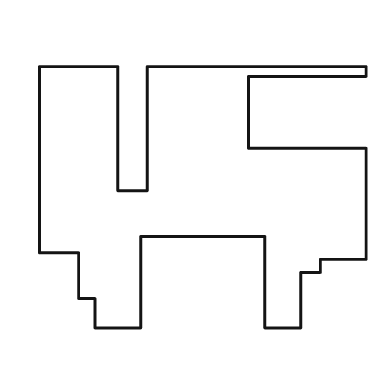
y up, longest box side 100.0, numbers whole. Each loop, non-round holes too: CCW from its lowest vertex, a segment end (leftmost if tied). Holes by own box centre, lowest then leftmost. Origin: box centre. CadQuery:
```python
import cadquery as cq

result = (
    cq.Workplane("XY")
    .moveTo(-33.0, -40.0)
    .lineTo(-19.0, -40.0)
    .lineTo(-19.0, -12.0)
    .lineTo(19.0, -12.0)
    .lineTo(19.0, -40.0)
    .lineTo(30.0, -40.0)
    .lineTo(30.0, -23.0)
    .lineTo(36.0, -23.0)
    .lineTo(36.0, -19.0)
    .lineTo(50.0, -19.0)
    .lineTo(50.0, 15.0)
    .lineTo(14.0, 15.0)
    .lineTo(14.0, 37.0)
    .lineTo(50.0, 37.0)
    .lineTo(50.0, 40.0)
    .lineTo(-17.0, 40.0)
    .lineTo(-17.0, 2.0)
    .lineTo(-26.0, 2.0)
    .lineTo(-26.0, 40.0)
    .lineTo(-50.0, 40.0)
    .lineTo(-50.0, -17.0)
    .lineTo(-38.0, -17.0)
    .lineTo(-38.0, -31.0)
    .lineTo(-33.0, -31.0)
    .close()
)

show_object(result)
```